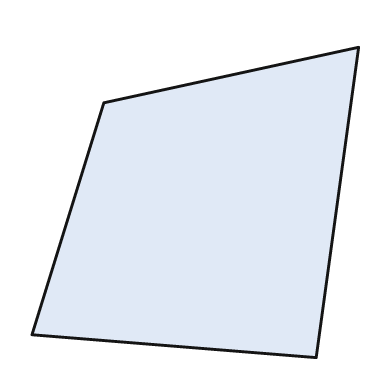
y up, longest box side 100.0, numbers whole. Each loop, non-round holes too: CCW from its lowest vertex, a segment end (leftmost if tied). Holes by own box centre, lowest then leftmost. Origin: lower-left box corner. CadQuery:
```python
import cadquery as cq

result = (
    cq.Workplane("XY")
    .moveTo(87.0, 0.0)
    .lineTo(100.0, 95.0)
    .lineTo(22.0, 78.0)
    .lineTo(0.0, 7.0)
    .close()
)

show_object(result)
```